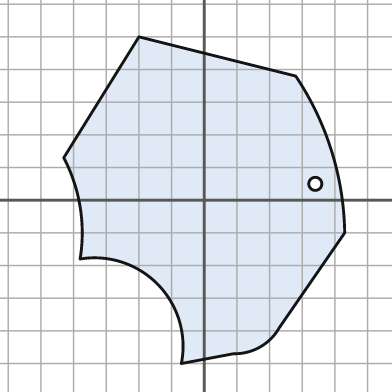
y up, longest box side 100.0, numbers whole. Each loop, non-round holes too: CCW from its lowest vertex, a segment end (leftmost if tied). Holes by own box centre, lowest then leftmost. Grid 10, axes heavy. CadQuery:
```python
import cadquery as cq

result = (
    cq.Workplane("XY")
    .moveTo(-7.0, -50.0)
    .lineTo(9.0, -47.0)
    .threePointArc((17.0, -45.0), (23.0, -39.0))
    .lineTo(43.0, -10.0)
    .threePointArc((39.0, 15.0), (28.0, 38.0))
    .lineTo(-20.0, 50.0)
    .lineTo(-43.0, 13.0)
    .threePointArc((-38.0, -2.0), (-38.0, -18.0))
    .threePointArc((-14.0, -26.0), (-7.0, -50.0))
    .close()
    .moveTo(34.0, 5.0)
    .circle(2.0)
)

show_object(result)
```